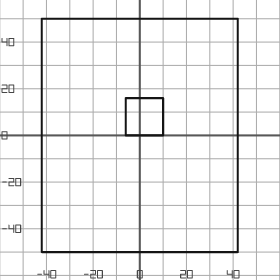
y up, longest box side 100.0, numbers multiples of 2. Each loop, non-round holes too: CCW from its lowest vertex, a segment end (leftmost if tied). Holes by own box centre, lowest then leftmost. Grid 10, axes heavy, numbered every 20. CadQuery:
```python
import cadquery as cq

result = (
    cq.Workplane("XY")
    .moveTo(-42.0, -50.0)
    .lineTo(42.0, -50.0)
    .lineTo(42.0, 50.0)
    .lineTo(-42.0, 50.0)
    .close()
    .moveTo(-6.0, 0.0)
    .lineTo(10.0, 0.0)
    .lineTo(10.0, 16.0)
    .lineTo(-6.0, 16.0)
    .close()
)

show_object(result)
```